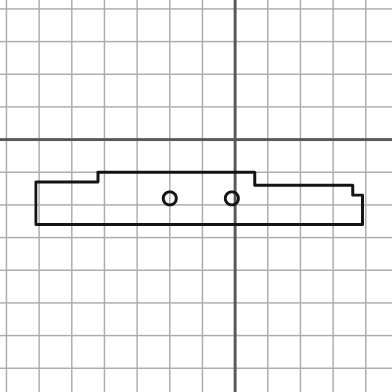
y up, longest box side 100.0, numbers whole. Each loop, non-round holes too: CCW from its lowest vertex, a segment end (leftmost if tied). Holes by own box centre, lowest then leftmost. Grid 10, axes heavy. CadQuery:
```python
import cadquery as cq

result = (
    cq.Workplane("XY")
    .moveTo(-61.0, -26.0)
    .lineTo(39.0, -26.0)
    .lineTo(39.0, -17.0)
    .lineTo(36.0, -17.0)
    .lineTo(36.0, -14.0)
    .lineTo(6.0, -14.0)
    .lineTo(6.0, -10.0)
    .lineTo(-42.0, -10.0)
    .lineTo(-42.0, -13.0)
    .lineTo(-61.0, -13.0)
    .close()
    .moveTo(-20.0, -18.0)
    .circle(2.0)
    .moveTo(-1.0, -18.0)
    .circle(2.0)
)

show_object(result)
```